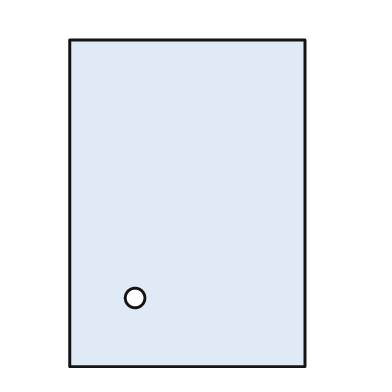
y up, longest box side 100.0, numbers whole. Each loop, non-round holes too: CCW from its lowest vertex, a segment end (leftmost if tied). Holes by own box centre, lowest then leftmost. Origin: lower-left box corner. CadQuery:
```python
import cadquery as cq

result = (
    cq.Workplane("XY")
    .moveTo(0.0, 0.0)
    .lineTo(72.0, 0.0)
    .lineTo(72.0, 100.0)
    .lineTo(0.0, 100.0)
    .close()
    .moveTo(20.0, 21.0)
    .circle(3.0)
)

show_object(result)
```